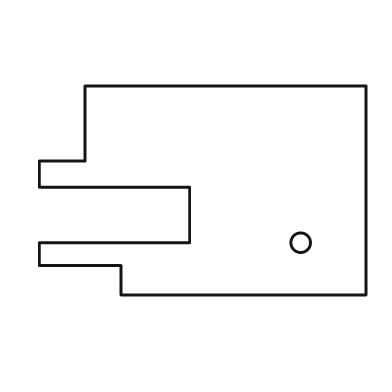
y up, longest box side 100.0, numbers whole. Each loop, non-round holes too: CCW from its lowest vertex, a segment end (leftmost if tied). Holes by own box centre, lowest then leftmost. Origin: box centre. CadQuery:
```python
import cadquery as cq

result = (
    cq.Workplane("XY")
    .moveTo(-25.0, -32.0)
    .lineTo(50.0, -32.0)
    .lineTo(50.0, 32.0)
    .lineTo(-36.0, 32.0)
    .lineTo(-36.0, 9.0)
    .lineTo(-50.0, 9.0)
    .lineTo(-50.0, 1.0)
    .lineTo(-4.0, 1.0)
    .lineTo(-4.0, -16.0)
    .lineTo(-50.0, -16.0)
    .lineTo(-50.0, -23.0)
    .lineTo(-25.0, -23.0)
    .close()
    .moveTo(30.0, -16.0)
    .circle(3.0)
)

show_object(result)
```